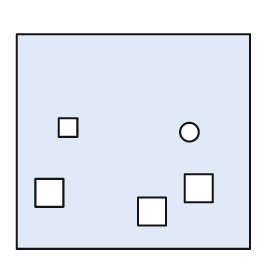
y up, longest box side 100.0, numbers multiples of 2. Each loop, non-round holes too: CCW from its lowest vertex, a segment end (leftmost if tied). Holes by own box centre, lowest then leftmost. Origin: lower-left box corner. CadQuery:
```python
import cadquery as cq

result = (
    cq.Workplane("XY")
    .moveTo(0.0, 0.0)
    .lineTo(100.0, 0.0)
    .lineTo(100.0, 92.0)
    .lineTo(0.0, 92.0)
    .close()
    .moveTo(52.0, 10.0)
    .lineTo(64.0, 10.0)
    .lineTo(64.0, 22.0)
    .lineTo(52.0, 22.0)
    .close()
    .moveTo(8.0, 18.0)
    .lineTo(20.0, 18.0)
    .lineTo(20.0, 30.0)
    .lineTo(8.0, 30.0)
    .close()
    .moveTo(72.0, 20.0)
    .lineTo(84.0, 20.0)
    .lineTo(84.0, 32.0)
    .lineTo(72.0, 32.0)
    .close()
    .moveTo(74.0, 50.0)
    .circle(4.0)
    .moveTo(18.0, 48.0)
    .lineTo(26.0, 48.0)
    .lineTo(26.0, 56.0)
    .lineTo(18.0, 56.0)
    .close()
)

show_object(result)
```